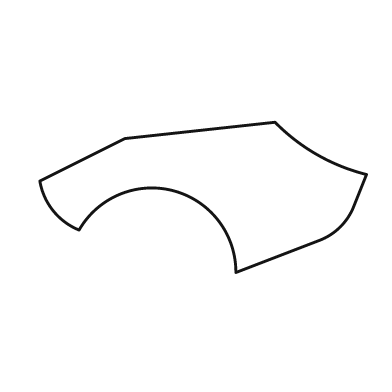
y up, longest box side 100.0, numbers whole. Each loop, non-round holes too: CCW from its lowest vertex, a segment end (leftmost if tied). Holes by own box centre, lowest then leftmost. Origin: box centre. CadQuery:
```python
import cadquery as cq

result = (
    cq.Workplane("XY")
    .moveTo(10.0, -23.0)
    .lineTo(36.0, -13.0)
    .threePointArc((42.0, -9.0), (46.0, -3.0))
    .lineTo(50.0, 7.0)
    .threePointArc((35.0, 13.0), (22.0, 23.0))
    .lineTo(-24.0, 18.0)
    .lineTo(-50.0, 5.0)
    .threePointArc((-46.0, -4.0), (-38.0, -10.0))
    .threePointArc((-9.0, 2.0), (10.0, -23.0))
    .close()
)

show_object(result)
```